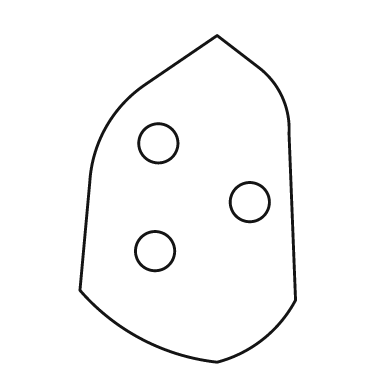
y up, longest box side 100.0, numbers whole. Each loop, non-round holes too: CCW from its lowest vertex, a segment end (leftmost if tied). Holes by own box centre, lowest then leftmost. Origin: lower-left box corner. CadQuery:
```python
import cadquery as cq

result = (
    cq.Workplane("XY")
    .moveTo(42.0, 0.0)
    .threePointArc((56.0, 7.0), (66.0, 19.0))
    .lineTo(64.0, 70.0)
    .threePointArc((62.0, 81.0), (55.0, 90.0))
    .lineTo(42.0, 100.0)
    .lineTo(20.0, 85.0)
    .threePointArc((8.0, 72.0), (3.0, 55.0))
    .lineTo(0.0, 22.0)
    .threePointArc((19.0, 7.0), (42.0, 0.0))
    .close()
    .moveTo(23.0, 34.0)
    .circle(6.0)
    .moveTo(52.0, 49.0)
    .circle(6.0)
    .moveTo(24.0, 67.0)
    .circle(6.0)
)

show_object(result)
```